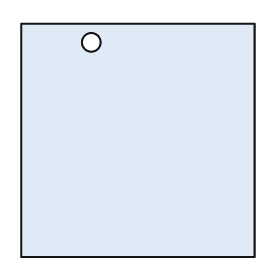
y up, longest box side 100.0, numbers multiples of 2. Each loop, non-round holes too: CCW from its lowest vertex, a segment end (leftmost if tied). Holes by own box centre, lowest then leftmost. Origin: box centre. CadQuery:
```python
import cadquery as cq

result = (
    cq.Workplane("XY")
    .moveTo(-50.0, -50.0)
    .lineTo(50.0, -50.0)
    .lineTo(50.0, 50.0)
    .lineTo(-50.0, 50.0)
    .close()
    .moveTo(-20.0, 42.0)
    .circle(4.0)
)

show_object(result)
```